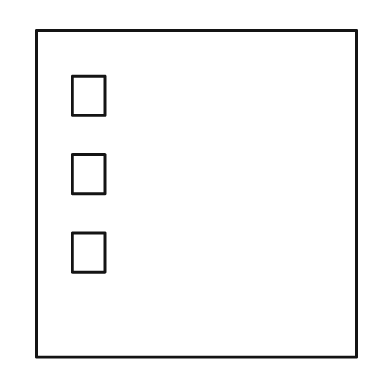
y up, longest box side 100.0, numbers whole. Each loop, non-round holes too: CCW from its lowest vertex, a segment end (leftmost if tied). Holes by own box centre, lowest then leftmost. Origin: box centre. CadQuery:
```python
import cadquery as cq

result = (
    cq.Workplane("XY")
    .moveTo(-49.0, -50.0)
    .lineTo(49.0, -50.0)
    .lineTo(49.0, 50.0)
    .lineTo(-49.0, 50.0)
    .close()
    .moveTo(-38.0, -24.0)
    .lineTo(-28.0, -24.0)
    .lineTo(-28.0, -12.0)
    .lineTo(-38.0, -12.0)
    .close()
    .moveTo(-38.0, 0.0)
    .lineTo(-28.0, 0.0)
    .lineTo(-28.0, 12.0)
    .lineTo(-38.0, 12.0)
    .close()
    .moveTo(-38.0, 24.0)
    .lineTo(-28.0, 24.0)
    .lineTo(-28.0, 36.0)
    .lineTo(-38.0, 36.0)
    .close()
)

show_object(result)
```